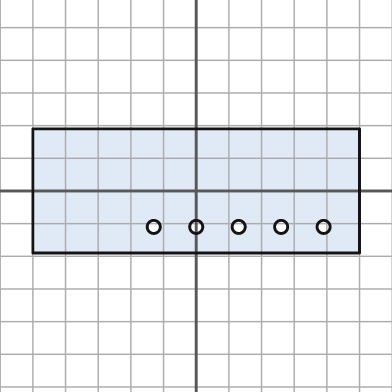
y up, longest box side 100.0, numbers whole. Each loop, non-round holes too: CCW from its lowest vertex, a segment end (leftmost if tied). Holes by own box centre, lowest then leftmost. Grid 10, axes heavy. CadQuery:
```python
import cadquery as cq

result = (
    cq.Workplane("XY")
    .moveTo(-50.0, -19.0)
    .lineTo(50.0, -19.0)
    .lineTo(50.0, 19.0)
    .lineTo(-50.0, 19.0)
    .close()
    .moveTo(-13.0, -11.0)
    .circle(2.0)
    .moveTo(0.0, -11.0)
    .circle(2.0)
    .moveTo(13.0, -11.0)
    .circle(2.0)
    .moveTo(26.0, -11.0)
    .circle(2.0)
    .moveTo(39.0, -11.0)
    .circle(2.0)
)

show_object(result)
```